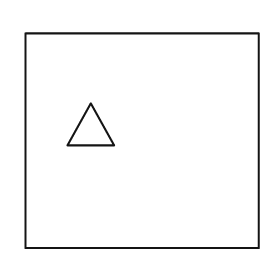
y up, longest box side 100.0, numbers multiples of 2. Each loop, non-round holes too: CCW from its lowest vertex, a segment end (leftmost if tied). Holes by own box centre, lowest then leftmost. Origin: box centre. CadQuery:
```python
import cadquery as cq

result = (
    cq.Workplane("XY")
    .moveTo(-50.0, -46.0)
    .lineTo(50.0, -46.0)
    .lineTo(50.0, 46.0)
    .lineTo(-50.0, 46.0)
    .close()
    .moveTo(-32.0, -2.0)
    .lineTo(-12.0, -2.0)
    .lineTo(-22.0, 16.0)
    .close()
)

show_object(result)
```